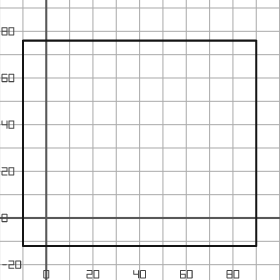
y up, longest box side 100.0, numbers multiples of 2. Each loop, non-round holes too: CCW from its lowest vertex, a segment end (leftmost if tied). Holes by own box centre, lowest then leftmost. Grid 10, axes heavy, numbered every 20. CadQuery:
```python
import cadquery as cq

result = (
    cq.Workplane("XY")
    .moveTo(-10.0, -12.0)
    .lineTo(90.0, -12.0)
    .lineTo(90.0, 76.0)
    .lineTo(-10.0, 76.0)
    .close()
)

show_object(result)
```